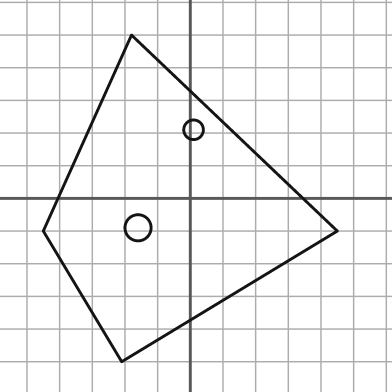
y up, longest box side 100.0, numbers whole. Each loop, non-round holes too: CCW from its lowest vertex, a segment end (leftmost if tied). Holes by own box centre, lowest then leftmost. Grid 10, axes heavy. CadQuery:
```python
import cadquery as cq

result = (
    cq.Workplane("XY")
    .moveTo(-21.0, -50.0)
    .lineTo(45.0, -10.0)
    .lineTo(-18.0, 50.0)
    .lineTo(-45.0, -10.0)
    .close()
    .moveTo(-16.0, -9.0)
    .circle(4.0)
    .moveTo(1.0, 21.0)
    .circle(3.0)
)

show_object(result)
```